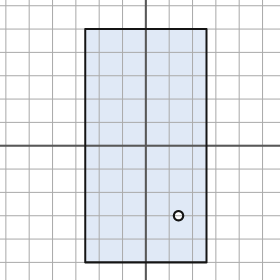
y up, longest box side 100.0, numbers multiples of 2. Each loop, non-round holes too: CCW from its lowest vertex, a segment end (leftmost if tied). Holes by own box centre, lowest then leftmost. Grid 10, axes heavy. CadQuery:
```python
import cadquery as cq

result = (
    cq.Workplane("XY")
    .moveTo(-26.0, -50.0)
    .lineTo(26.0, -50.0)
    .lineTo(26.0, 50.0)
    .lineTo(-26.0, 50.0)
    .close()
    .moveTo(14.0, -30.0)
    .circle(2.0)
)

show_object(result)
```